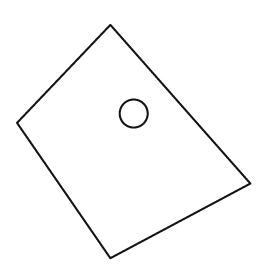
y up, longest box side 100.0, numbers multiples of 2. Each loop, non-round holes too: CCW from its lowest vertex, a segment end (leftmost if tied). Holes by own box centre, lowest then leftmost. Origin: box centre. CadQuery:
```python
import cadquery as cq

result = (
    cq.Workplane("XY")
    .moveTo(-10.0, -50.0)
    .lineTo(50.0, -18.0)
    .lineTo(-10.0, 50.0)
    .lineTo(-50.0, 8.0)
    .close()
    .moveTo(0.0, 12.0)
    .circle(6.0)
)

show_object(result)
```